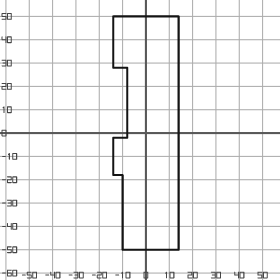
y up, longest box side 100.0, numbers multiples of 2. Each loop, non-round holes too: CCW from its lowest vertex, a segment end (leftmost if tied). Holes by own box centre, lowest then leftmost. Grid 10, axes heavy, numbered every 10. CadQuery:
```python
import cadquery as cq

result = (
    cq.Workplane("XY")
    .moveTo(-10.0, -50.0)
    .lineTo(14.0, -50.0)
    .lineTo(14.0, 50.0)
    .lineTo(-14.0, 50.0)
    .lineTo(-14.0, 28.0)
    .lineTo(-8.0, 28.0)
    .lineTo(-8.0, -2.0)
    .lineTo(-14.0, -2.0)
    .lineTo(-14.0, -18.0)
    .lineTo(-10.0, -18.0)
    .close()
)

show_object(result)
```